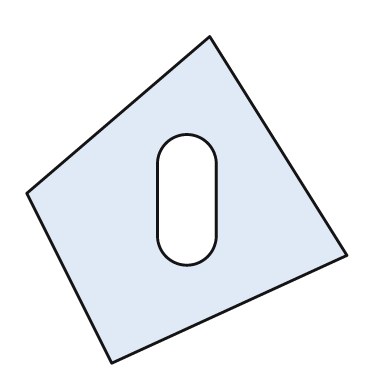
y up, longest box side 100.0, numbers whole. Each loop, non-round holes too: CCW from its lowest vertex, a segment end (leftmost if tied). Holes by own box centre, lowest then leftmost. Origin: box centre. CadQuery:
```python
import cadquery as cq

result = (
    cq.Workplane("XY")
    .moveTo(-23.0, -50.0)
    .lineTo(49.0, -17.0)
    .lineTo(7.0, 50.0)
    .lineTo(-49.0, 2.0)
    .close()
    .moveTo(-9.0, -11.0)
    .threePointArc((0.0, -20.0), (9.0, -11.0))
    .lineTo(9.0, 11.0)
    .threePointArc((0.0, 20.0), (-9.0, 11.0))
    .close()
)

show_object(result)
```